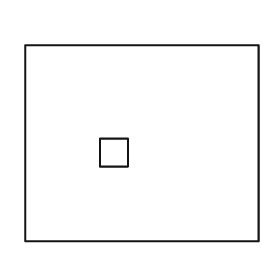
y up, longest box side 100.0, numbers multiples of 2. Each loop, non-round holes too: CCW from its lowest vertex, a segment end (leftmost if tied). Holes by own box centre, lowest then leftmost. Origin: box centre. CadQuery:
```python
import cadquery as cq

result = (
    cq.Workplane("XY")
    .moveTo(-50.0, -42.0)
    .lineTo(50.0, -42.0)
    .lineTo(50.0, 42.0)
    .lineTo(-50.0, 42.0)
    .close()
    .moveTo(-18.0, -10.0)
    .lineTo(-6.0, -10.0)
    .lineTo(-6.0, 2.0)
    .lineTo(-18.0, 2.0)
    .close()
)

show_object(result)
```